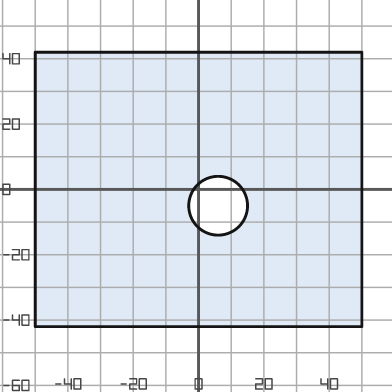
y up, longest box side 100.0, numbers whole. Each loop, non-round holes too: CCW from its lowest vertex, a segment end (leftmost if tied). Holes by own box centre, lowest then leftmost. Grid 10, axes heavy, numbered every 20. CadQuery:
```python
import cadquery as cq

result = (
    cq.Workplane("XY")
    .moveTo(-50.0, -42.0)
    .lineTo(50.0, -42.0)
    .lineTo(50.0, 42.0)
    .lineTo(-50.0, 42.0)
    .close()
    .moveTo(6.0, -5.0)
    .circle(9.0)
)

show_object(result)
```